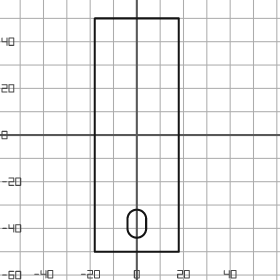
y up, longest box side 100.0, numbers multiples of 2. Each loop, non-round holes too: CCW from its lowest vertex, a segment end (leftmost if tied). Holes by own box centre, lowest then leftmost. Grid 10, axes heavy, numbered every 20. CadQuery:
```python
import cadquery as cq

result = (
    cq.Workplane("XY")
    .moveTo(-18.0, -50.0)
    .lineTo(18.0, -50.0)
    .lineTo(18.0, 50.0)
    .lineTo(-18.0, 50.0)
    .close()
    .moveTo(-4.0, -40.0)
    .threePointArc((0.0, -44.0), (4.0, -40.0))
    .lineTo(4.0, -36.0)
    .threePointArc((0.0, -32.0), (-4.0, -36.0))
    .close()
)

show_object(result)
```